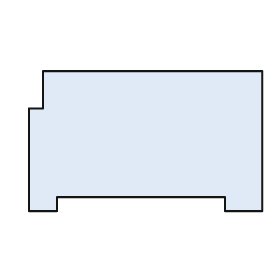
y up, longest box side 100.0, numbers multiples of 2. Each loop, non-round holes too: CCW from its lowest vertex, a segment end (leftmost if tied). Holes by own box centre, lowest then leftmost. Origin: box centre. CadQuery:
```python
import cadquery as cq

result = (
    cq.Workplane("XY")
    .moveTo(-50.0, -30.0)
    .lineTo(-38.0, -30.0)
    .lineTo(-38.0, -24.0)
    .lineTo(34.0, -24.0)
    .lineTo(34.0, -30.0)
    .lineTo(50.0, -30.0)
    .lineTo(50.0, 30.0)
    .lineTo(-44.0, 30.0)
    .lineTo(-44.0, 14.0)
    .lineTo(-50.0, 14.0)
    .close()
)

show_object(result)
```